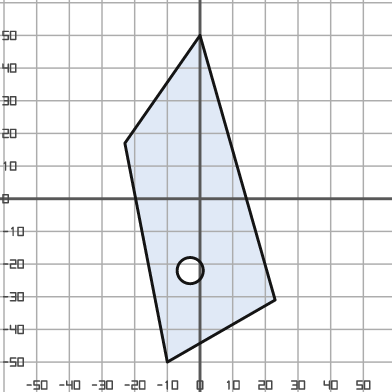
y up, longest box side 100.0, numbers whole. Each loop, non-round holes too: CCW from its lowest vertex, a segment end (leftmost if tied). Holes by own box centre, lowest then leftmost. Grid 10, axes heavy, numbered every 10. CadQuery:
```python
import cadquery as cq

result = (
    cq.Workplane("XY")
    .moveTo(-10.0, -50.0)
    .lineTo(23.0, -31.0)
    .lineTo(0.0, 50.0)
    .lineTo(-23.0, 17.0)
    .close()
    .moveTo(-3.0, -22.0)
    .circle(4.0)
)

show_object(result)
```